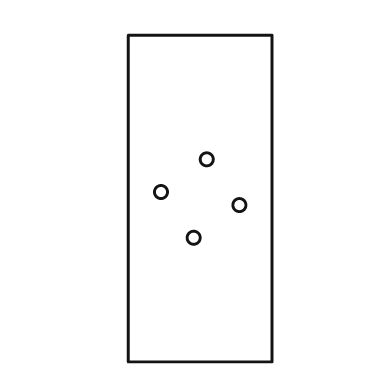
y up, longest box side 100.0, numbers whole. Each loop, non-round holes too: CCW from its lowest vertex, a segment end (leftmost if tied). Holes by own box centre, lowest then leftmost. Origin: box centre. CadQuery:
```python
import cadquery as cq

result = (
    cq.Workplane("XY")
    .moveTo(-22.0, -50.0)
    .lineTo(22.0, -50.0)
    .lineTo(22.0, 50.0)
    .lineTo(-22.0, 50.0)
    .close()
    .moveTo(-2.0, -12.0)
    .circle(2.0)
    .moveTo(12.0, -2.0)
    .circle(2.0)
    .moveTo(-12.0, 2.0)
    .circle(2.0)
    .moveTo(2.0, 12.0)
    .circle(2.0)
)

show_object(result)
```